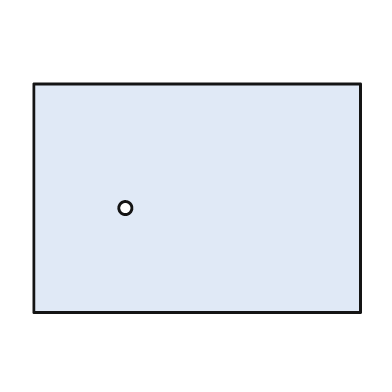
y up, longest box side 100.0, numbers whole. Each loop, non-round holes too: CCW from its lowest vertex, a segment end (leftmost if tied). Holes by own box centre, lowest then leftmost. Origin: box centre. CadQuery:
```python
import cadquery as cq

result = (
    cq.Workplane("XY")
    .moveTo(-50.0, -35.0)
    .lineTo(50.0, -35.0)
    .lineTo(50.0, 35.0)
    .lineTo(-50.0, 35.0)
    .close()
    .moveTo(-22.0, -3.0)
    .circle(2.0)
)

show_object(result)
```